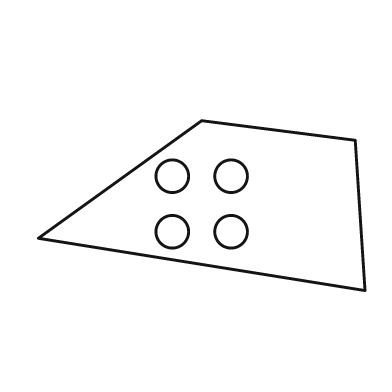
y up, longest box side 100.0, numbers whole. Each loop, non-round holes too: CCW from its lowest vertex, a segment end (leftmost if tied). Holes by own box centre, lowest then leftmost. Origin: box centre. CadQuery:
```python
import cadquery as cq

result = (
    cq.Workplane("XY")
    .moveTo(50.0, -26.0)
    .lineTo(47.0, 20.0)
    .lineTo(0.0, 26.0)
    .lineTo(-50.0, -10.0)
    .close()
    .moveTo(-9.0, -8.0)
    .circle(5.0)
    .moveTo(9.0, -8.0)
    .circle(5.0)
    .moveTo(-9.0, 9.0)
    .circle(5.0)
    .moveTo(9.0, 9.0)
    .circle(5.0)
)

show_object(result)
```